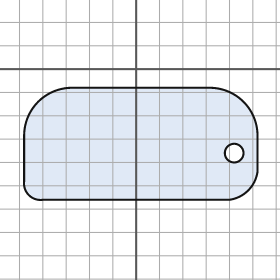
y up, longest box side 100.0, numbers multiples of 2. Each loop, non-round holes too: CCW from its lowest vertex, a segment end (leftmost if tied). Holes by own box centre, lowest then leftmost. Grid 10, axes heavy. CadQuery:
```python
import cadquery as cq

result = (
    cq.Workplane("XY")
    .moveTo(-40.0, -56.0)
    .lineTo(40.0, -56.0)
    .threePointArc((48.0, -52.0), (52.0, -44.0))
    .lineTo(52.0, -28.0)
    .threePointArc((46.0, -14.0), (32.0, -8.0))
    .lineTo(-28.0, -8.0)
    .threePointArc((-42.0, -14.0), (-48.0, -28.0))
    .lineTo(-48.0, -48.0)
    .threePointArc((-46.0, -54.0), (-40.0, -56.0))
    .close()
    .moveTo(42.0, -36.0)
    .circle(4.0)
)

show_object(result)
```